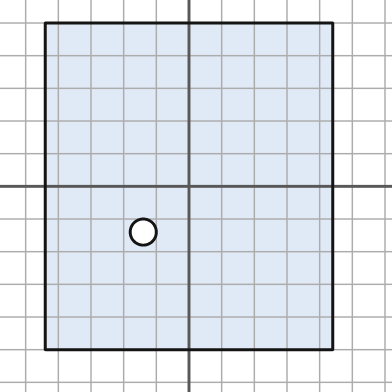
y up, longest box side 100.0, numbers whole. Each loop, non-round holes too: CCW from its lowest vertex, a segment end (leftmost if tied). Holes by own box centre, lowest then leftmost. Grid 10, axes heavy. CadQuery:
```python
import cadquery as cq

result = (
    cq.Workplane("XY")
    .moveTo(-44.0, -50.0)
    .lineTo(44.0, -50.0)
    .lineTo(44.0, 50.0)
    .lineTo(-44.0, 50.0)
    .close()
    .moveTo(-14.0, -14.0)
    .circle(4.0)
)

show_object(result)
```